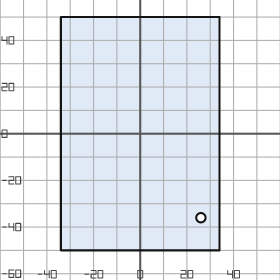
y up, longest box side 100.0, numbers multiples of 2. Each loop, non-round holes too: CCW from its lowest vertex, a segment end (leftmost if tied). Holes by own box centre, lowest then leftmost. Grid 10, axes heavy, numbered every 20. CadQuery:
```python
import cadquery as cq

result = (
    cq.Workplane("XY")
    .moveTo(-34.0, -50.0)
    .lineTo(34.0, -50.0)
    .lineTo(34.0, 50.0)
    .lineTo(-34.0, 50.0)
    .close()
    .moveTo(26.0, -36.0)
    .circle(2.0)
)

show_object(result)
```